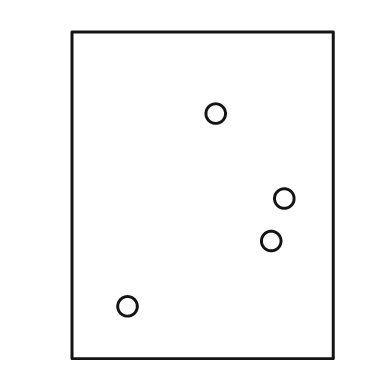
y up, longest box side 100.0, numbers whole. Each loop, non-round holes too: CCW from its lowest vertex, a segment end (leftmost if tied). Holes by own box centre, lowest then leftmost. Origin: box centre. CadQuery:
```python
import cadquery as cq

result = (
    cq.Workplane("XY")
    .moveTo(-40.0, -50.0)
    .lineTo(40.0, -50.0)
    .lineTo(40.0, 50.0)
    .lineTo(-40.0, 50.0)
    .close()
    .moveTo(-23.0, -34.0)
    .circle(3.0)
    .moveTo(21.0, -14.0)
    .circle(3.0)
    .moveTo(25.0, -1.0)
    .circle(3.0)
    .moveTo(4.0, 25.0)
    .circle(3.0)
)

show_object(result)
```